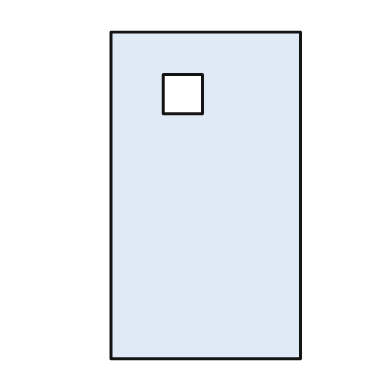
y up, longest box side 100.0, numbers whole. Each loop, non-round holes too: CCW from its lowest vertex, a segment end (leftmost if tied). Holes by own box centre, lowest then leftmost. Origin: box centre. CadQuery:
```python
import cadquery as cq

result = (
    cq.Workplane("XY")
    .moveTo(-29.0, -50.0)
    .lineTo(29.0, -50.0)
    .lineTo(29.0, 50.0)
    .lineTo(-29.0, 50.0)
    .close()
    .moveTo(-13.0, 25.0)
    .lineTo(-1.0, 25.0)
    .lineTo(-1.0, 37.0)
    .lineTo(-13.0, 37.0)
    .close()
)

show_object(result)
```